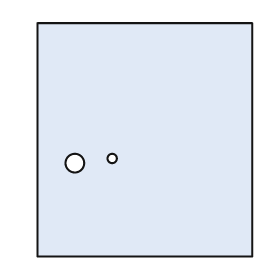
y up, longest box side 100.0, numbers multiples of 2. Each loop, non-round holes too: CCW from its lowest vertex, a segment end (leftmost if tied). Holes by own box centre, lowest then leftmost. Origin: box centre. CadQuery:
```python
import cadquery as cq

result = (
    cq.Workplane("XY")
    .moveTo(-46.0, -50.0)
    .lineTo(46.0, -50.0)
    .lineTo(46.0, 50.0)
    .lineTo(-46.0, 50.0)
    .close()
    .moveTo(-30.0, -10.0)
    .circle(4.0)
    .moveTo(-14.0, -8.0)
    .circle(2.0)
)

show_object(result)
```